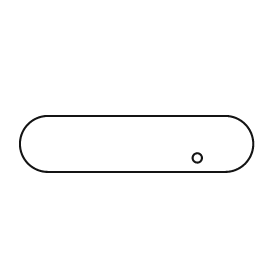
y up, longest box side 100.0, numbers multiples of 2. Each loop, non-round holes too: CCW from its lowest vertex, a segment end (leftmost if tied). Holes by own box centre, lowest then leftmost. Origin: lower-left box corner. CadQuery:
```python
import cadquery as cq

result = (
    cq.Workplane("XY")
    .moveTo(12.0, 0.0)
    .lineTo(88.0, 0.0)
    .threePointArc((100.0, 12.0), (88.0, 24.0))
    .lineTo(12.0, 24.0)
    .threePointArc((0.0, 12.0), (12.0, 0.0))
    .close()
    .moveTo(76.0, 6.0)
    .circle(2.0)
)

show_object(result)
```